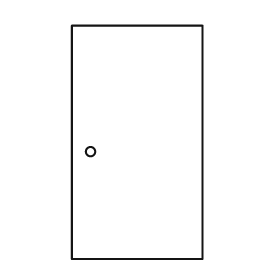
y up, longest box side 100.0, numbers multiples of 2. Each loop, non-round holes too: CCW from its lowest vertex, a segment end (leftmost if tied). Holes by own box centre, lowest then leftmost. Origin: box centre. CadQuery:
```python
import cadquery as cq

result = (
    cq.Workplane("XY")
    .moveTo(-28.0, -50.0)
    .lineTo(28.0, -50.0)
    .lineTo(28.0, 50.0)
    .lineTo(-28.0, 50.0)
    .close()
    .moveTo(-20.0, -4.0)
    .circle(2.0)
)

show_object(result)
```